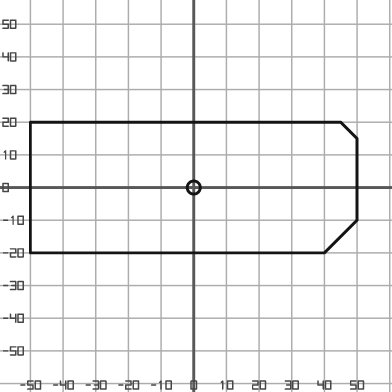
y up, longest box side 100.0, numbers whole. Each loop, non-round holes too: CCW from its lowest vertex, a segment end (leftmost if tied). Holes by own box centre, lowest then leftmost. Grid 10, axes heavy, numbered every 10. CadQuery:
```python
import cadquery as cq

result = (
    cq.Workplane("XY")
    .moveTo(-50.0, -20.0)
    .lineTo(40.0, -20.0)
    .lineTo(50.0, -10.0)
    .lineTo(50.0, 15.0)
    .lineTo(45.0, 20.0)
    .lineTo(-50.0, 20.0)
    .close()
    .moveTo(0.0, 0.0)
    .circle(2.0)
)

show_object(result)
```